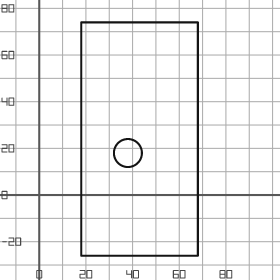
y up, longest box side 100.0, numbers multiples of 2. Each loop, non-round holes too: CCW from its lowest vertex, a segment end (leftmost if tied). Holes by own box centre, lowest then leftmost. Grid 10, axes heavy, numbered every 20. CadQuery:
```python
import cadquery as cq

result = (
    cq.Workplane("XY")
    .moveTo(18.0, -26.0)
    .lineTo(68.0, -26.0)
    .lineTo(68.0, 74.0)
    .lineTo(18.0, 74.0)
    .close()
    .moveTo(38.0, 18.0)
    .circle(6.0)
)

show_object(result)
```